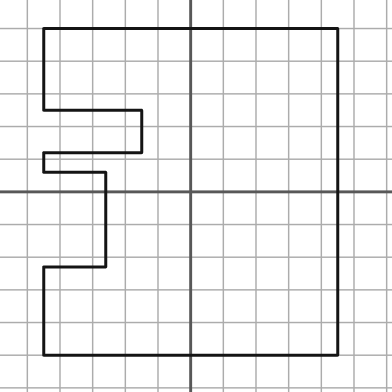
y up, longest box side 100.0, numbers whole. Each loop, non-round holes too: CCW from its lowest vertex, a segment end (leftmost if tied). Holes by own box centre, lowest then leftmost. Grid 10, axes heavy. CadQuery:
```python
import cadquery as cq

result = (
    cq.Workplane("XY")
    .moveTo(-45.0, -50.0)
    .lineTo(45.0, -50.0)
    .lineTo(45.0, 50.0)
    .lineTo(-45.0, 50.0)
    .lineTo(-45.0, 25.0)
    .lineTo(-15.0, 25.0)
    .lineTo(-15.0, 12.0)
    .lineTo(-45.0, 12.0)
    .lineTo(-45.0, 6.0)
    .lineTo(-26.0, 6.0)
    .lineTo(-26.0, -23.0)
    .lineTo(-45.0, -23.0)
    .close()
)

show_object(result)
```